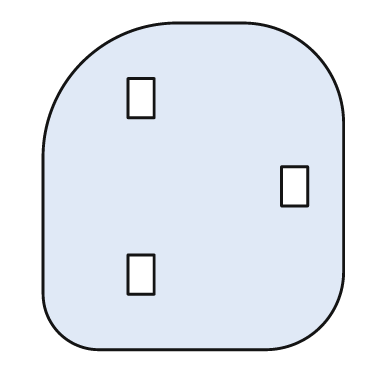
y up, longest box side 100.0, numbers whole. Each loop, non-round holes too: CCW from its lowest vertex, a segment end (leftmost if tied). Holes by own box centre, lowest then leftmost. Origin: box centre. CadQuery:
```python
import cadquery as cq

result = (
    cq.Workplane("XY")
    .moveTo(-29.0, -50.0)
    .lineTo(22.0, -50.0)
    .threePointArc((39.0, -43.0), (46.0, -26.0))
    .lineTo(46.0, 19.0)
    .threePointArc((37.0, 41.0), (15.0, 50.0))
    .lineTo(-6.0, 50.0)
    .threePointArc((-34.0, 38.0), (-46.0, 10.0))
    .lineTo(-46.0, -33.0)
    .threePointArc((-41.0, -45.0), (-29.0, -50.0))
    .close()
    .moveTo(-20.0, -33.0)
    .lineTo(-12.0, -33.0)
    .lineTo(-12.0, -21.0)
    .lineTo(-20.0, -21.0)
    .close()
    .moveTo(27.0, -6.0)
    .lineTo(35.0, -6.0)
    .lineTo(35.0, 6.0)
    .lineTo(27.0, 6.0)
    .close()
    .moveTo(-20.0, 21.0)
    .lineTo(-12.0, 21.0)
    .lineTo(-12.0, 33.0)
    .lineTo(-20.0, 33.0)
    .close()
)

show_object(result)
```